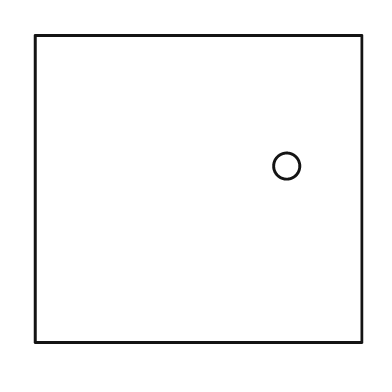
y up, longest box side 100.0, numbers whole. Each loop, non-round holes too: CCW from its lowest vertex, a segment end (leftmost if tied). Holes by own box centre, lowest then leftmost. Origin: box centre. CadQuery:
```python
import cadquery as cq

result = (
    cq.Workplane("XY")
    .moveTo(-50.0, -47.0)
    .lineTo(50.0, -47.0)
    .lineTo(50.0, 47.0)
    .lineTo(-50.0, 47.0)
    .close()
    .moveTo(27.0, 7.0)
    .circle(4.0)
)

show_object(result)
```